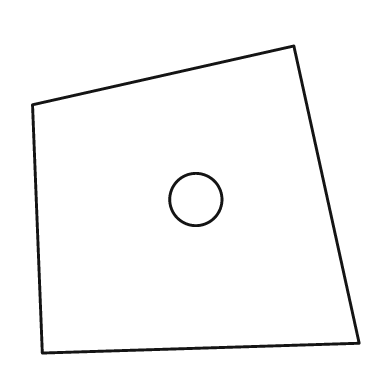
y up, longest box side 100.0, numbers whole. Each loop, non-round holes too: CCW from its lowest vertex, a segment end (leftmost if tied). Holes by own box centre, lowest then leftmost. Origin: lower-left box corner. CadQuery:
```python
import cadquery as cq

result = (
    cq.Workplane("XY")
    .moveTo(3.0, 0.0)
    .lineTo(100.0, 3.0)
    .lineTo(80.0, 94.0)
    .lineTo(0.0, 76.0)
    .close()
    .moveTo(50.0, 47.0)
    .circle(8.0)
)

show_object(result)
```